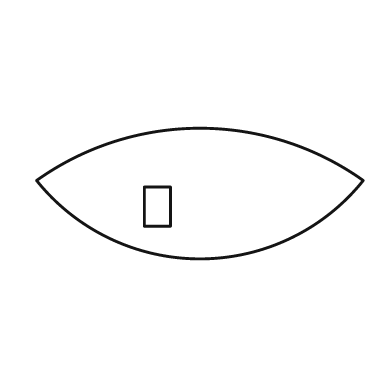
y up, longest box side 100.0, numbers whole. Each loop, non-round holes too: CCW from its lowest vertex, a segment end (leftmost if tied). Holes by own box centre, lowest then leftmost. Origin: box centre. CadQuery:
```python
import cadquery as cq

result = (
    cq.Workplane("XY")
    .moveTo(-50.0, 4.0)
    .threePointArc((0.0, -20.0), (50.0, 4.0))
    .threePointArc((0.0, 20.0), (-50.0, 4.0))
    .close()
    .moveTo(-17.0, -10.0)
    .lineTo(-9.0, -10.0)
    .lineTo(-9.0, 2.0)
    .lineTo(-17.0, 2.0)
    .close()
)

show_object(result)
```